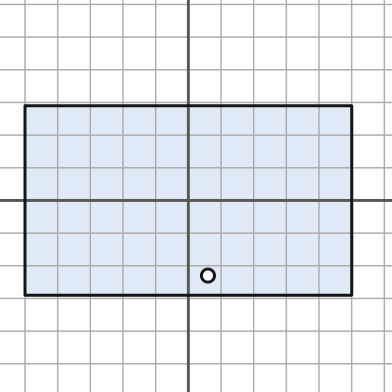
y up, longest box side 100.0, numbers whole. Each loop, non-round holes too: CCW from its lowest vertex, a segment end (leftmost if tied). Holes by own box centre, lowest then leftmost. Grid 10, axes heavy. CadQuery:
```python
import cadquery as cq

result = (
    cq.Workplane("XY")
    .moveTo(-50.0, -29.0)
    .lineTo(50.0, -29.0)
    .lineTo(50.0, 29.0)
    .lineTo(-50.0, 29.0)
    .close()
    .moveTo(6.0, -23.0)
    .circle(2.0)
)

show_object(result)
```